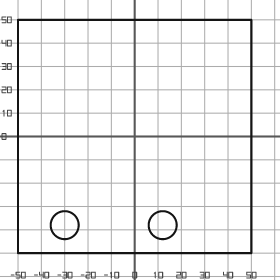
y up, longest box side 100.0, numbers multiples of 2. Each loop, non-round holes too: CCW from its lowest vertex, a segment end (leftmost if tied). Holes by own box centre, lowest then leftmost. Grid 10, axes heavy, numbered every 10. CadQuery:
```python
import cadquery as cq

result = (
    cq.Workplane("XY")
    .moveTo(-50.0, -50.0)
    .lineTo(50.0, -50.0)
    .lineTo(50.0, 50.0)
    .lineTo(-50.0, 50.0)
    .close()
    .moveTo(-30.0, -38.0)
    .circle(6.0)
    .moveTo(12.0, -38.0)
    .circle(6.0)
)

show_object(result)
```